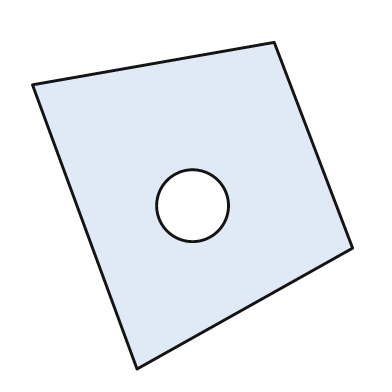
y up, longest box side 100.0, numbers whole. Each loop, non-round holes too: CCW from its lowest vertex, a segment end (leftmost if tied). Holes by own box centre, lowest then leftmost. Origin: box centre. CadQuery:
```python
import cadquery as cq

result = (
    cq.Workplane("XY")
    .moveTo(-17.0, -50.0)
    .lineTo(49.0, -13.0)
    .lineTo(25.0, 50.0)
    .lineTo(-49.0, 37.0)
    .close()
    .moveTo(0.0, 0.0)
    .circle(11.0)
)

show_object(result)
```